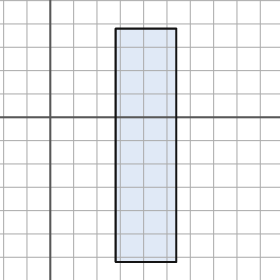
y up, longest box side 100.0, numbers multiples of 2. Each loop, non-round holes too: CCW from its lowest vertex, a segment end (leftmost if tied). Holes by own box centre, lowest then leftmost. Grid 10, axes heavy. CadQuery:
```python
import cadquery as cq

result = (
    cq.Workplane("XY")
    .moveTo(28.0, -62.0)
    .lineTo(54.0, -62.0)
    .lineTo(54.0, 38.0)
    .lineTo(28.0, 38.0)
    .close()
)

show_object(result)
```